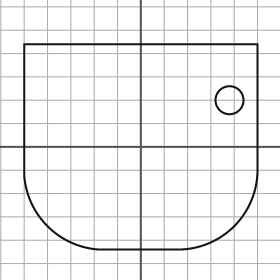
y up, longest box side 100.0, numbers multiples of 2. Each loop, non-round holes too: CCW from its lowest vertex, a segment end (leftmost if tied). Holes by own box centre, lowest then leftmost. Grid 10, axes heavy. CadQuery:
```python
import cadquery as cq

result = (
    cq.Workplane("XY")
    .moveTo(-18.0, -44.0)
    .lineTo(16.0, -44.0)
    .threePointArc((40.0, -34.0), (50.0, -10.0))
    .lineTo(50.0, 44.0)
    .lineTo(-50.0, 44.0)
    .lineTo(-50.0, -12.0)
    .threePointArc((-40.0, -34.0), (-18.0, -44.0))
    .close()
    .moveTo(38.0, 20.0)
    .circle(6.0)
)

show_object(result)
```